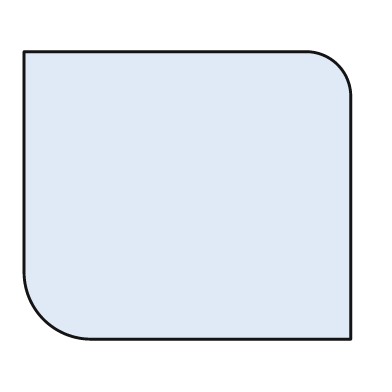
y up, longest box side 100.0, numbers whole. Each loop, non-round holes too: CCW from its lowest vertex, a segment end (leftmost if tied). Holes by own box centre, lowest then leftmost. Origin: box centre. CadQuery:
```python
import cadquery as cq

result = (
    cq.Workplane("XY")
    .moveTo(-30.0, -44.0)
    .lineTo(50.0, -44.0)
    .lineTo(50.0, 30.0)
    .threePointArc((46.0, 40.0), (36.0, 44.0))
    .lineTo(-50.0, 44.0)
    .lineTo(-50.0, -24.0)
    .threePointArc((-44.0, -38.0), (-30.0, -44.0))
    .close()
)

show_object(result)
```